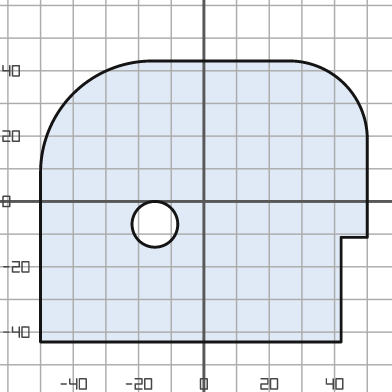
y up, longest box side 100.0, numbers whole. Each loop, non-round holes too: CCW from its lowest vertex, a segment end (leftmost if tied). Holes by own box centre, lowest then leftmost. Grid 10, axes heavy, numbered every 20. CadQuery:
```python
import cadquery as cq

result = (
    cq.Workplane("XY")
    .moveTo(-50.0, -43.0)
    .lineTo(42.0, -43.0)
    .lineTo(42.0, -11.0)
    .lineTo(50.0, -11.0)
    .lineTo(50.0, 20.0)
    .threePointArc((43.0, 36.0), (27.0, 43.0))
    .lineTo(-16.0, 43.0)
    .threePointArc((-40.0, 33.0), (-50.0, 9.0))
    .close()
    .moveTo(-15.0, -7.0)
    .circle(7.0)
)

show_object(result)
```